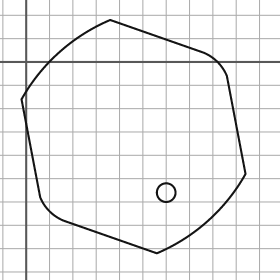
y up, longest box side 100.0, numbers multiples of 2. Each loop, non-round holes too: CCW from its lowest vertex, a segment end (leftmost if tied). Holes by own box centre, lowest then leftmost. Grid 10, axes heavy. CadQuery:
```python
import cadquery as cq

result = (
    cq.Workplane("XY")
    .moveTo(56.0, -82.0)
    .threePointArc((78.0, -68.0), (94.0, -48.0))
    .lineTo(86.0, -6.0)
    .threePointArc((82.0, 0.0), (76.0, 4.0))
    .lineTo(36.0, 18.0)
    .threePointArc((14.0, 4.0), (-2.0, -16.0))
    .lineTo(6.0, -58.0)
    .threePointArc((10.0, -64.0), (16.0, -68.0))
    .close()
    .moveTo(60.0, -56.0)
    .circle(4.0)
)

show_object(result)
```